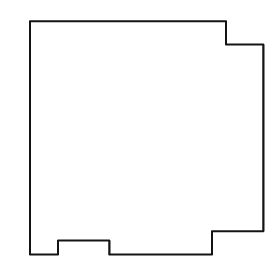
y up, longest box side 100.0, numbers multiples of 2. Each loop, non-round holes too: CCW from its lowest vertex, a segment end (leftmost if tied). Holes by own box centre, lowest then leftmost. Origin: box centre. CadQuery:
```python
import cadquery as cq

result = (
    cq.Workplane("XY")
    .moveTo(-50.0, -50.0)
    .lineTo(-38.0, -50.0)
    .lineTo(-38.0, -44.0)
    .lineTo(-16.0, -44.0)
    .lineTo(-16.0, -50.0)
    .lineTo(28.0, -50.0)
    .lineTo(28.0, -40.0)
    .lineTo(50.0, -40.0)
    .lineTo(50.0, 40.0)
    .lineTo(34.0, 40.0)
    .lineTo(34.0, 50.0)
    .lineTo(-50.0, 50.0)
    .close()
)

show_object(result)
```